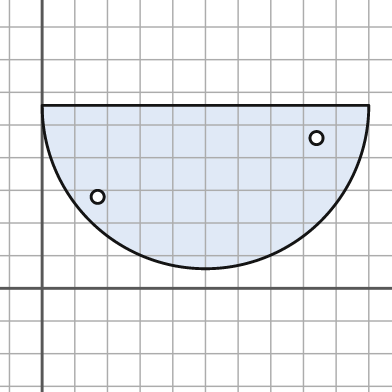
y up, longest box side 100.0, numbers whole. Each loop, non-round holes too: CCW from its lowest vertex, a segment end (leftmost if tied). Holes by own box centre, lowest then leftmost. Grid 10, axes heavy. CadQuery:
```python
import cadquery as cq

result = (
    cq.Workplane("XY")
    .moveTo(0.0, 56.0)
    .threePointArc((50.0, 6.0), (100.0, 56.0))
    .close()
    .moveTo(17.0, 28.0)
    .circle(2.0)
    .moveTo(84.0, 46.0)
    .circle(2.0)
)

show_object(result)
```